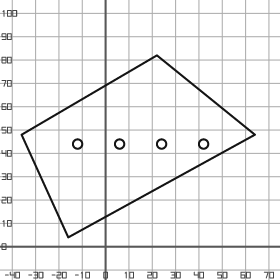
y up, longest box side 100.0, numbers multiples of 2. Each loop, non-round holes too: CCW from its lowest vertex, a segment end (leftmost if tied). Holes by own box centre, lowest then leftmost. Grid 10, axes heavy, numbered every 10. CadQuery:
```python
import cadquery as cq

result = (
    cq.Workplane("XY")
    .moveTo(-16.0, 4.0)
    .lineTo(64.0, 48.0)
    .lineTo(22.0, 82.0)
    .lineTo(-36.0, 48.0)
    .close()
    .moveTo(-12.0, 44.0)
    .circle(2.0)
    .moveTo(6.0, 44.0)
    .circle(2.0)
    .moveTo(24.0, 44.0)
    .circle(2.0)
    .moveTo(42.0, 44.0)
    .circle(2.0)
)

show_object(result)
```